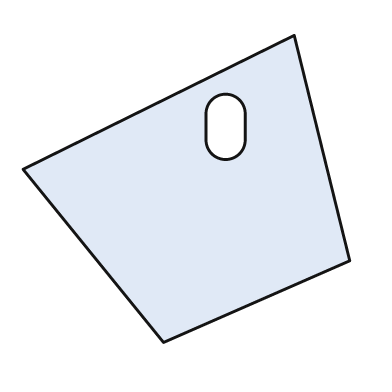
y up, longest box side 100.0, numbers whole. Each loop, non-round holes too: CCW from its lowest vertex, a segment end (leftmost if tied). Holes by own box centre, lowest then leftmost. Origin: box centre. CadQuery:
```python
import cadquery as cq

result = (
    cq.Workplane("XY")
    .moveTo(-7.0, -47.0)
    .lineTo(50.0, -22.0)
    .lineTo(33.0, 47.0)
    .lineTo(-50.0, 6.0)
    .close()
    .moveTo(6.0, 15.0)
    .threePointArc((12.0, 9.0), (18.0, 15.0))
    .lineTo(18.0, 23.0)
    .threePointArc((12.0, 29.0), (6.0, 23.0))
    .close()
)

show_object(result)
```